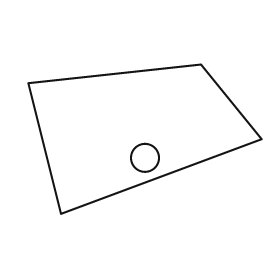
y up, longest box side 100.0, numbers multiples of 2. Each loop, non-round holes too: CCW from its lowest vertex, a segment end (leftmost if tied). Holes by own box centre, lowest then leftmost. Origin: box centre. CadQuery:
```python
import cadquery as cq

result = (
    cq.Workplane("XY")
    .moveTo(-36.0, -32.0)
    .lineTo(50.0, 0.0)
    .lineTo(24.0, 32.0)
    .lineTo(-50.0, 24.0)
    .close()
    .moveTo(0.0, -8.0)
    .circle(6.0)
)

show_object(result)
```